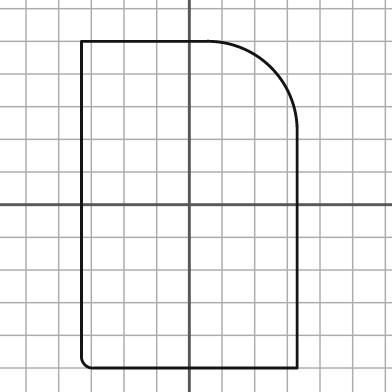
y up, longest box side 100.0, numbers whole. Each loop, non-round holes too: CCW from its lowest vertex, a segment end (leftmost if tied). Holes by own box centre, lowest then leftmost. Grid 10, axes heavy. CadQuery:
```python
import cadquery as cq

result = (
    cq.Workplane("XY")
    .moveTo(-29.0, -50.0)
    .lineTo(33.0, -50.0)
    .lineTo(33.0, 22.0)
    .threePointArc((25.0, 42.0), (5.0, 50.0))
    .lineTo(-33.0, 50.0)
    .lineTo(-33.0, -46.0)
    .threePointArc((-32.0, -49.0), (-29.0, -50.0))
    .close()
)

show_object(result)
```